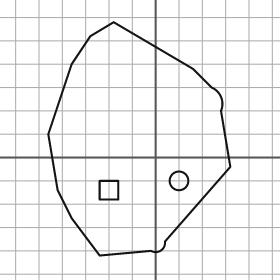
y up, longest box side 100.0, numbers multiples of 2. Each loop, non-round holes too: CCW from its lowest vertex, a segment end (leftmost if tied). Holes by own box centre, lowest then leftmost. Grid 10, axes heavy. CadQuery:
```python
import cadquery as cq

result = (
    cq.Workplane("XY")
    .moveTo(-24.0, -42.0)
    .lineTo(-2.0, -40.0)
    .threePointArc((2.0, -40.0), (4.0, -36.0))
    .lineTo(32.0, -4.0)
    .lineTo(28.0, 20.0)
    .threePointArc((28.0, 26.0), (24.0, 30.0))
    .lineTo(16.0, 38.0)
    .lineTo(-18.0, 58.0)
    .lineTo(-28.0, 52.0)
    .lineTo(-36.0, 40.0)
    .lineTo(-46.0, 10.0)
    .lineTo(-42.0, -14.0)
    .lineTo(-36.0, -26.0)
    .close()
    .moveTo(-24.0, -18.0)
    .lineTo(-16.0, -18.0)
    .lineTo(-16.0, -10.0)
    .lineTo(-24.0, -10.0)
    .close()
    .moveTo(10.0, -10.0)
    .circle(4.0)
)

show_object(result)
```